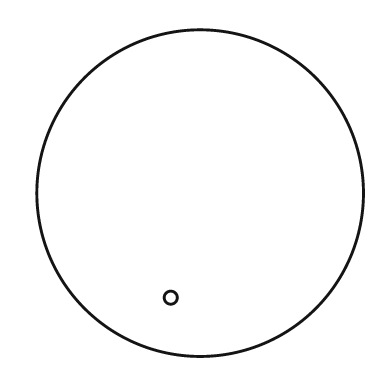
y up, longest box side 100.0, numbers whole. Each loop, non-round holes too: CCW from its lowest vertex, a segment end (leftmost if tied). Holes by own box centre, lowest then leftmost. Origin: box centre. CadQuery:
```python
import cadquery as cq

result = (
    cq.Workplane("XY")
    .moveTo(0.0, 0.0)
    .circle(50.0)
    .moveTo(-9.0, -32.0)
    .circle(2.0)
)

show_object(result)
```